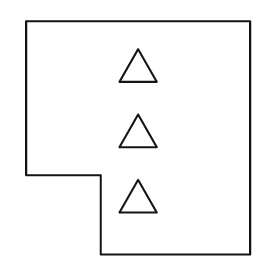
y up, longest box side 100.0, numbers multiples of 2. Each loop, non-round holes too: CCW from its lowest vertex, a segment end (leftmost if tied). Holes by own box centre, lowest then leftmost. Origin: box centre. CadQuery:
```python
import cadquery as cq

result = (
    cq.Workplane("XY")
    .moveTo(-16.0, -50.0)
    .lineTo(48.0, -50.0)
    .lineTo(48.0, 50.0)
    .lineTo(-48.0, 50.0)
    .lineTo(-48.0, -16.0)
    .lineTo(-16.0, -16.0)
    .close()
    .moveTo(-8.0, -32.0)
    .lineTo(8.0, -32.0)
    .lineTo(0.0, -18.0)
    .close()
    .moveTo(-8.0, -4.0)
    .lineTo(8.0, -4.0)
    .lineTo(0.0, 10.0)
    .close()
    .moveTo(-8.0, 24.0)
    .lineTo(8.0, 24.0)
    .lineTo(0.0, 38.0)
    .close()
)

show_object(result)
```